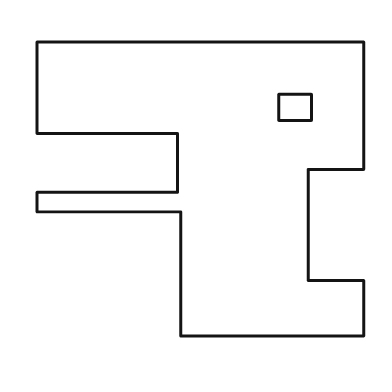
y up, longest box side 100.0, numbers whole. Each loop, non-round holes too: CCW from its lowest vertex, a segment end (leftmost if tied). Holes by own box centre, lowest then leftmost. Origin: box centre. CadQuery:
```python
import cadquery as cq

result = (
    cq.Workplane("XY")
    .moveTo(-6.0, -45.0)
    .lineTo(50.0, -45.0)
    .lineTo(50.0, -28.0)
    .lineTo(33.0, -28.0)
    .lineTo(33.0, 6.0)
    .lineTo(50.0, 6.0)
    .lineTo(50.0, 45.0)
    .lineTo(-50.0, 45.0)
    .lineTo(-50.0, 17.0)
    .lineTo(-7.0, 17.0)
    .lineTo(-7.0, -1.0)
    .lineTo(-50.0, -1.0)
    .lineTo(-50.0, -7.0)
    .lineTo(-6.0, -7.0)
    .close()
    .moveTo(24.0, 21.0)
    .lineTo(34.0, 21.0)
    .lineTo(34.0, 29.0)
    .lineTo(24.0, 29.0)
    .close()
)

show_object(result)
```